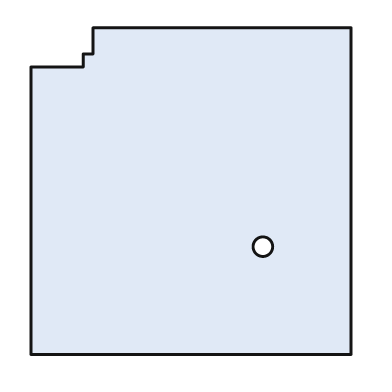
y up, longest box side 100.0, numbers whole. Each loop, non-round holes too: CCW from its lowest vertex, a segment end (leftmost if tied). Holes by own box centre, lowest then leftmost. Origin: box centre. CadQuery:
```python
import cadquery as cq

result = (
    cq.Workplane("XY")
    .moveTo(-49.0, -50.0)
    .lineTo(49.0, -50.0)
    .lineTo(49.0, 50.0)
    .lineTo(-30.0, 50.0)
    .lineTo(-30.0, 42.0)
    .lineTo(-33.0, 42.0)
    .lineTo(-33.0, 38.0)
    .lineTo(-49.0, 38.0)
    .close()
    .moveTo(22.0, -17.0)
    .circle(3.0)
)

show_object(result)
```